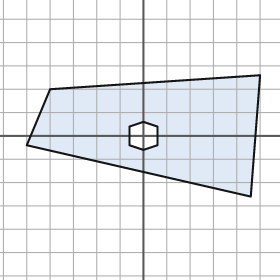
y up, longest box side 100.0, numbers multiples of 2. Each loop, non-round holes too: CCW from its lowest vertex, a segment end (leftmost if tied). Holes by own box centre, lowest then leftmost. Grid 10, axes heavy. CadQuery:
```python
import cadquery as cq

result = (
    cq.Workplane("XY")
    .moveTo(46.0, -26.0)
    .lineTo(50.0, 26.0)
    .lineTo(-40.0, 20.0)
    .lineTo(-50.0, -4.0)
    .close()
    .moveTo(0.0, -6.0)
    .lineTo(6.0, -4.0)
    .lineTo(6.0, 4.0)
    .lineTo(0.0, 6.0)
    .lineTo(-6.0, 4.0)
    .lineTo(-6.0, -4.0)
    .close()
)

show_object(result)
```